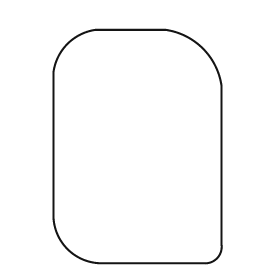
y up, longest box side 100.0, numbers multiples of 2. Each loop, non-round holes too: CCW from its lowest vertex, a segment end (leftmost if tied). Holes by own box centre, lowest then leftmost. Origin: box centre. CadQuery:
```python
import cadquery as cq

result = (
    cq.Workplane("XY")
    .moveTo(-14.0, -50.0)
    .lineTo(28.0, -50.0)
    .threePointArc((34.0, -48.0), (36.0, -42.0))
    .lineTo(36.0, 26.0)
    .threePointArc((28.0, 42.0), (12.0, 50.0))
    .lineTo(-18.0, 50.0)
    .threePointArc((-30.0, 44.0), (-36.0, 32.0))
    .lineTo(-36.0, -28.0)
    .threePointArc((-30.0, -44.0), (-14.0, -50.0))
    .close()
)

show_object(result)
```